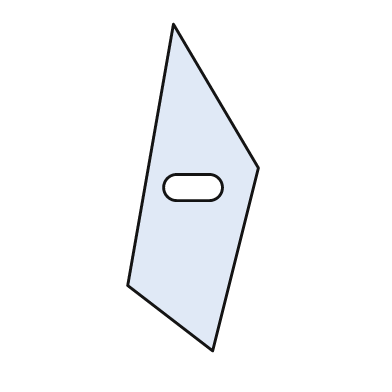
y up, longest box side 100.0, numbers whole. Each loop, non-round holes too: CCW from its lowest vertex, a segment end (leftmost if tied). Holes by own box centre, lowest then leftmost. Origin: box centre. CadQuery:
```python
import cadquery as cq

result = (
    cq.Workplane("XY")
    .moveTo(6.0, -50.0)
    .lineTo(20.0, 6.0)
    .lineTo(-6.0, 50.0)
    .lineTo(-20.0, -30.0)
    .close()
    .moveTo(-5.0, -4.0)
    .lineTo(5.0, -4.0)
    .threePointArc((9.0, 0.0), (5.0, 4.0))
    .lineTo(-5.0, 4.0)
    .threePointArc((-9.0, 0.0), (-5.0, -4.0))
    .close()
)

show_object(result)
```